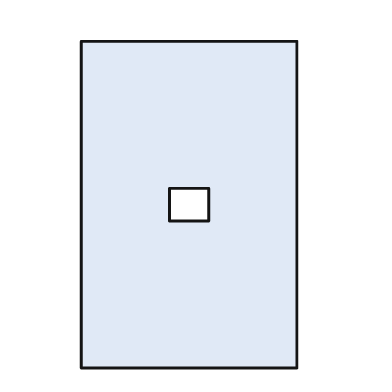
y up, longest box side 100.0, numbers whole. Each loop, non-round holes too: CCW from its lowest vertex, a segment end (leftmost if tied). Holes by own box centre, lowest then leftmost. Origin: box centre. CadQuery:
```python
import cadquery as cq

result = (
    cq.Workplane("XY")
    .moveTo(-33.0, -50.0)
    .lineTo(33.0, -50.0)
    .lineTo(33.0, 50.0)
    .lineTo(-33.0, 50.0)
    .close()
    .moveTo(-6.0, -5.0)
    .lineTo(6.0, -5.0)
    .lineTo(6.0, 5.0)
    .lineTo(-6.0, 5.0)
    .close()
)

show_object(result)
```